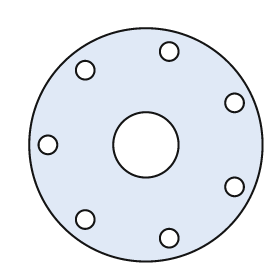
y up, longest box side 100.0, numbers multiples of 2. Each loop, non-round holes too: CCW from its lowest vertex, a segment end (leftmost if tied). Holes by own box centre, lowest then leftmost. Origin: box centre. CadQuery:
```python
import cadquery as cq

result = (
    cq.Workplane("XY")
    .moveTo(0.0, 0.0)
    .circle(50.0)
    .moveTo(10.0, -40.0)
    .circle(4.0)
    .moveTo(-26.0, -32.0)
    .circle(4.0)
    .moveTo(38.0, -18.0)
    .circle(4.0)
    .moveTo(-42.0, 0.0)
    .circle(4.0)
    .moveTo(0.0, 0.0)
    .circle(14.0)
    .moveTo(38.0, 18.0)
    .circle(4.0)
    .moveTo(-26.0, 32.0)
    .circle(4.0)
    .moveTo(10.0, 40.0)
    .circle(4.0)
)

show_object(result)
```